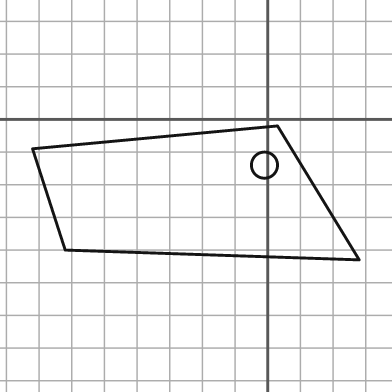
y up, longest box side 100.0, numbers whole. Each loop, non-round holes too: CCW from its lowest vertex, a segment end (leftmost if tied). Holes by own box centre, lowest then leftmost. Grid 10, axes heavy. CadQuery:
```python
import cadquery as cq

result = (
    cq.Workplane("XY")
    .moveTo(28.0, -43.0)
    .lineTo(3.0, -2.0)
    .lineTo(-72.0, -9.0)
    .lineTo(-62.0, -40.0)
    .close()
    .moveTo(-1.0, -14.0)
    .circle(4.0)
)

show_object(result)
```